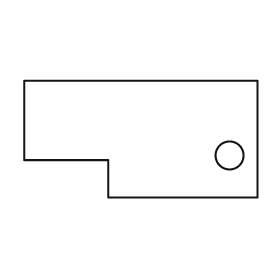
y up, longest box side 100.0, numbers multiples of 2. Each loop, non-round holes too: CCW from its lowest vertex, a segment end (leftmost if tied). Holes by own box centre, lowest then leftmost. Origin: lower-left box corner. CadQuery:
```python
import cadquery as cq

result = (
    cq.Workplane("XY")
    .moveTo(36.0, 0.0)
    .lineTo(100.0, 0.0)
    .lineTo(100.0, 50.0)
    .lineTo(0.0, 50.0)
    .lineTo(0.0, 16.0)
    .lineTo(36.0, 16.0)
    .close()
    .moveTo(88.0, 18.0)
    .circle(6.0)
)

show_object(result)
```